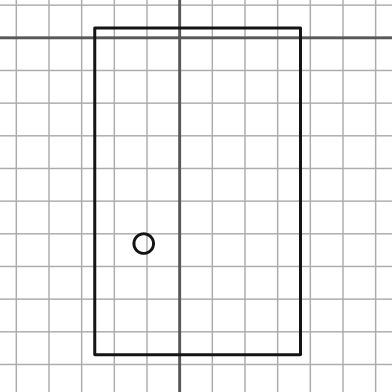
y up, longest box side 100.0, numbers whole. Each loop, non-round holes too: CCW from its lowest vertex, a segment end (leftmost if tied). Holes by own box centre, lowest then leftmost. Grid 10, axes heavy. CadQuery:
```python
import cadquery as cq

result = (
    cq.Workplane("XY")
    .moveTo(-26.0, -97.0)
    .lineTo(37.0, -97.0)
    .lineTo(37.0, 3.0)
    .lineTo(-26.0, 3.0)
    .close()
    .moveTo(-11.0, -63.0)
    .circle(3.0)
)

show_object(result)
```